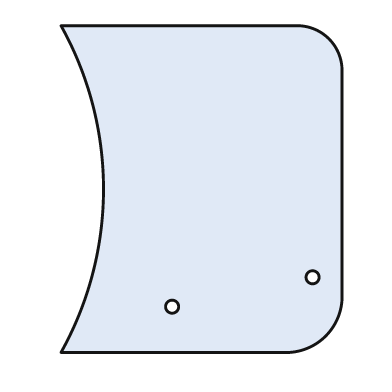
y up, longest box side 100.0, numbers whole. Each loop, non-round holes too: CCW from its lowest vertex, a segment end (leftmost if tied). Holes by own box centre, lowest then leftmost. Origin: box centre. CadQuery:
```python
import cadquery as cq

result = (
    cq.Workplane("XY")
    .moveTo(-43.0, -50.0)
    .lineTo(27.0, -50.0)
    .threePointArc((38.0, -45.0), (43.0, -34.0))
    .lineTo(43.0, 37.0)
    .threePointArc((39.0, 46.0), (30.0, 50.0))
    .lineTo(-43.0, 50.0)
    .threePointArc((-30.0, 0.0), (-43.0, -50.0))
    .close()
    .moveTo(-9.0, -36.0)
    .circle(2.0)
    .moveTo(34.0, -27.0)
    .circle(2.0)
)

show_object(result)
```